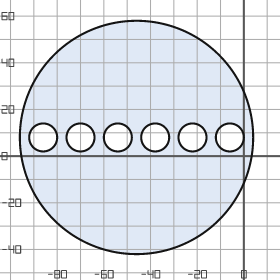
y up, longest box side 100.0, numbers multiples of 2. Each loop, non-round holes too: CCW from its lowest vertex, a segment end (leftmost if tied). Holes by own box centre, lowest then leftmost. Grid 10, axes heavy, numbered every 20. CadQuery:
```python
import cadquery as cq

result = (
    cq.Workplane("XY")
    .moveTo(-46.0, 8.0)
    .circle(50.0)
    .moveTo(-86.0, 8.0)
    .circle(6.0)
    .moveTo(-70.0, 8.0)
    .circle(6.0)
    .moveTo(-54.0, 8.0)
    .circle(6.0)
    .moveTo(-38.0, 8.0)
    .circle(6.0)
    .moveTo(-22.0, 8.0)
    .circle(6.0)
    .moveTo(-6.0, 8.0)
    .circle(6.0)
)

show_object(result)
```